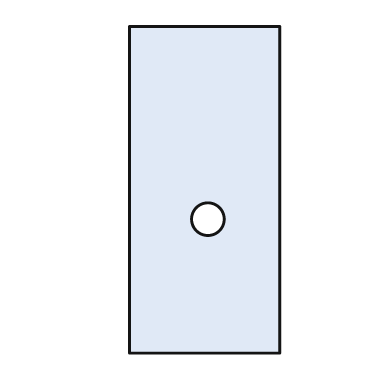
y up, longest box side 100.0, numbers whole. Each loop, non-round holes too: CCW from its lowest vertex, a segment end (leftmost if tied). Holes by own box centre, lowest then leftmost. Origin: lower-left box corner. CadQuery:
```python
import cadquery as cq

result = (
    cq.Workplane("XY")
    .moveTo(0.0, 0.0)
    .lineTo(46.0, 0.0)
    .lineTo(46.0, 100.0)
    .lineTo(0.0, 100.0)
    .close()
    .moveTo(24.0, 41.0)
    .circle(5.0)
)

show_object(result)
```